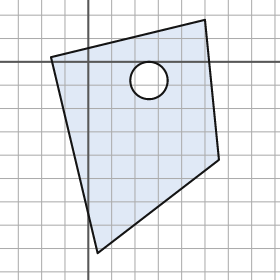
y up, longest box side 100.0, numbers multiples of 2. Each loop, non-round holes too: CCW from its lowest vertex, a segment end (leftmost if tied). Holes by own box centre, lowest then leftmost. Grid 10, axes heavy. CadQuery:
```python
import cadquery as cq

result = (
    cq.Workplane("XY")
    .moveTo(4.0, -82.0)
    .lineTo(56.0, -42.0)
    .lineTo(50.0, 18.0)
    .lineTo(-16.0, 2.0)
    .close()
    .moveTo(26.0, -8.0)
    .circle(8.0)
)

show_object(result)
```